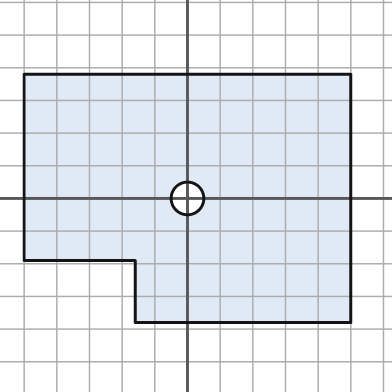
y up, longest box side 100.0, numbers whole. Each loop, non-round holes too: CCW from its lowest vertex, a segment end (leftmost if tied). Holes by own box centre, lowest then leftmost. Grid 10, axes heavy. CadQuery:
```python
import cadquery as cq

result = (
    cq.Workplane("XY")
    .moveTo(-16.0, -38.0)
    .lineTo(50.0, -38.0)
    .lineTo(50.0, 38.0)
    .lineTo(-50.0, 38.0)
    .lineTo(-50.0, -19.0)
    .lineTo(-16.0, -19.0)
    .close()
    .moveTo(0.0, 0.0)
    .circle(5.0)
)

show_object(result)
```